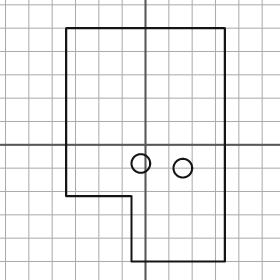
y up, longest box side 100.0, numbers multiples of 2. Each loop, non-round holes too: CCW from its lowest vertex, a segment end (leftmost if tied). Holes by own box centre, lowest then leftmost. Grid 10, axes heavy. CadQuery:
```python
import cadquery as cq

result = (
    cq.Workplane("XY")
    .moveTo(-6.0, -50.0)
    .lineTo(34.0, -50.0)
    .lineTo(34.0, 50.0)
    .lineTo(-34.0, 50.0)
    .lineTo(-34.0, -22.0)
    .lineTo(-6.0, -22.0)
    .close()
    .moveTo(16.0, -10.0)
    .circle(4.0)
    .moveTo(-2.0, -8.0)
    .circle(4.0)
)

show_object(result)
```